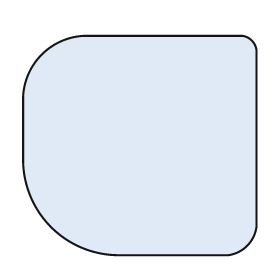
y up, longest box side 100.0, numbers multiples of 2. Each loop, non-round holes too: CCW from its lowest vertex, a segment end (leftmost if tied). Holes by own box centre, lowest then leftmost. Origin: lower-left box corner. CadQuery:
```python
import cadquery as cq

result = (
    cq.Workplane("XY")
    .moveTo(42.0, 0.0)
    .lineTo(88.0, 0.0)
    .threePointArc((96.0, 4.0), (100.0, 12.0))
    .lineTo(100.0, 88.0)
    .threePointArc((98.0, 92.0), (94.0, 94.0))
    .lineTo(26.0, 94.0)
    .threePointArc((8.0, 86.0), (0.0, 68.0))
    .lineTo(0.0, 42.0)
    .threePointArc((12.0, 12.0), (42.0, 0.0))
    .close()
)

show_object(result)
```